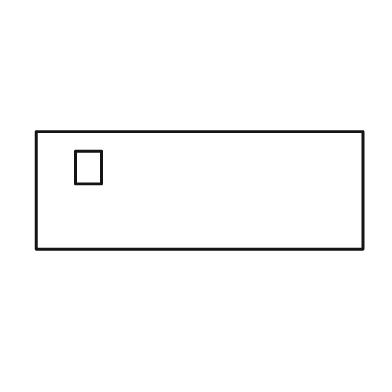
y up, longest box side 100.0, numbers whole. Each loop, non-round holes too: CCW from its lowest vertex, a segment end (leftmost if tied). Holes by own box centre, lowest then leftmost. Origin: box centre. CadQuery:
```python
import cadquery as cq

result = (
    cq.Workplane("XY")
    .moveTo(-50.0, -18.0)
    .lineTo(50.0, -18.0)
    .lineTo(50.0, 18.0)
    .lineTo(-50.0, 18.0)
    .close()
    .moveTo(-38.0, 2.0)
    .lineTo(-30.0, 2.0)
    .lineTo(-30.0, 12.0)
    .lineTo(-38.0, 12.0)
    .close()
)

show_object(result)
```